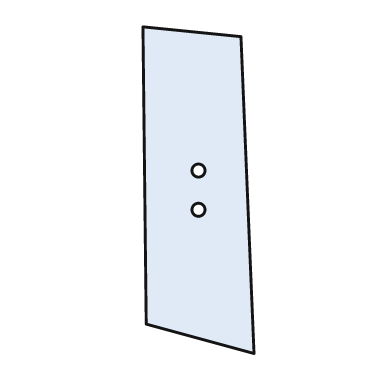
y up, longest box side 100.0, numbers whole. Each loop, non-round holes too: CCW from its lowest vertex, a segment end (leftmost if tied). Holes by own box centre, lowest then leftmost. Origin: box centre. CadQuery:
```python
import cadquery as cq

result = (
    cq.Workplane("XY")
    .moveTo(17.0, -50.0)
    .lineTo(13.0, 47.0)
    .lineTo(-17.0, 50.0)
    .lineTo(-16.0, -41.0)
    .close()
    .moveTo(0.0, -6.0)
    .circle(2.0)
    .moveTo(0.0, 6.0)
    .circle(2.0)
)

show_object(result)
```